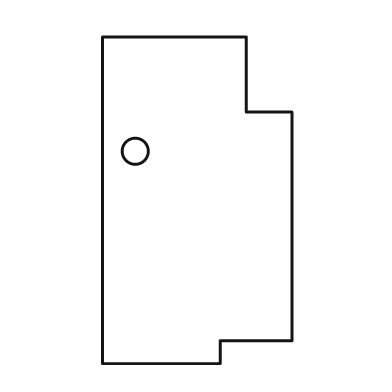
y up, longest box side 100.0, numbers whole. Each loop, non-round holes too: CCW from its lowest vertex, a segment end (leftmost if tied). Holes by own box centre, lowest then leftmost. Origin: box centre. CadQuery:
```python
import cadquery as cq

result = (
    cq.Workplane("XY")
    .moveTo(-29.0, -50.0)
    .lineTo(7.0, -50.0)
    .lineTo(7.0, -43.0)
    .lineTo(29.0, -43.0)
    .lineTo(29.0, 27.0)
    .lineTo(15.0, 27.0)
    .lineTo(15.0, 50.0)
    .lineTo(-29.0, 50.0)
    .close()
    .moveTo(-19.0, 15.0)
    .circle(4.0)
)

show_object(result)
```